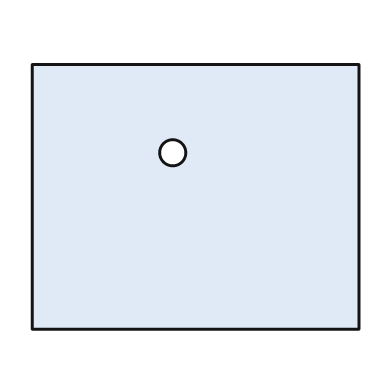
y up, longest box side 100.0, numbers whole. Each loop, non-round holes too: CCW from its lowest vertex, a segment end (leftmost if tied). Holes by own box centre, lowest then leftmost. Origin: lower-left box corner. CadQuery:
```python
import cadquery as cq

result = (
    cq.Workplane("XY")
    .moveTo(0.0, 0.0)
    .lineTo(100.0, 0.0)
    .lineTo(100.0, 81.0)
    .lineTo(0.0, 81.0)
    .close()
    .moveTo(43.0, 54.0)
    .circle(4.0)
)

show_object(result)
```